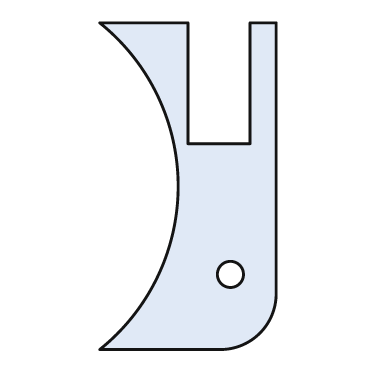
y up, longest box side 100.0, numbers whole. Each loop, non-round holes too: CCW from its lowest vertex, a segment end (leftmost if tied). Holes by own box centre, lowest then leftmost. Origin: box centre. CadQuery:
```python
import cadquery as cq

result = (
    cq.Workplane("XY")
    .moveTo(-27.0, -50.0)
    .lineTo(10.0, -50.0)
    .threePointArc((22.0, -45.0), (27.0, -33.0))
    .lineTo(27.0, 50.0)
    .lineTo(19.0, 50.0)
    .lineTo(19.0, 13.0)
    .lineTo(0.0, 13.0)
    .lineTo(0.0, 50.0)
    .lineTo(-27.0, 50.0)
    .threePointArc((-3.0, 0.0), (-27.0, -50.0))
    .close()
    .moveTo(13.0, -27.0)
    .circle(4.0)
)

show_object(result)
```